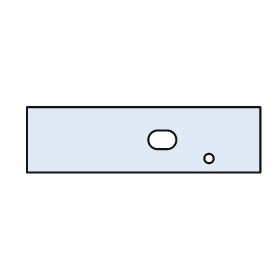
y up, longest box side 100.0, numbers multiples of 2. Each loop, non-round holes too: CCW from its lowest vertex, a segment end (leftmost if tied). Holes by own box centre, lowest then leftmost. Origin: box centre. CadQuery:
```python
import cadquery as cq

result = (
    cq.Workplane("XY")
    .moveTo(-50.0, -14.0)
    .lineTo(50.0, -14.0)
    .lineTo(50.0, 14.0)
    .lineTo(-50.0, 14.0)
    .close()
    .moveTo(28.0, -8.0)
    .circle(2.0)
    .moveTo(6.0, -4.0)
    .lineTo(10.0, -4.0)
    .threePointArc((14.0, 0.0), (10.0, 4.0))
    .lineTo(6.0, 4.0)
    .threePointArc((2.0, 0.0), (6.0, -4.0))
    .close()
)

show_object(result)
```